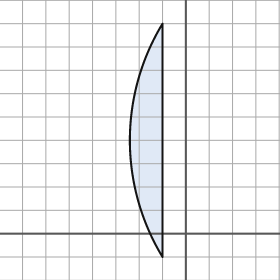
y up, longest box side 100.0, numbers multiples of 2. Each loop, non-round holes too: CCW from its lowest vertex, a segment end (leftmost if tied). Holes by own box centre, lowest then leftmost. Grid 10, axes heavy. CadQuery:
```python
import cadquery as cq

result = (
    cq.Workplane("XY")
    .moveTo(-10.0, -10.0)
    .lineTo(-10.0, 90.0)
    .threePointArc((-24.0, 40.0), (-10.0, -10.0))
    .close()
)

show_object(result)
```